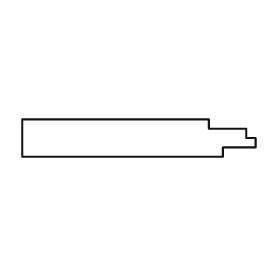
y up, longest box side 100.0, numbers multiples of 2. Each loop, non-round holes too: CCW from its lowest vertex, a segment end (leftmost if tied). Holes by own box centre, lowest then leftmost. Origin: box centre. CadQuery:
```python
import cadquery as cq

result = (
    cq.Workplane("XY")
    .moveTo(-50.0, -8.0)
    .lineTo(36.0, -8.0)
    .lineTo(36.0, -4.0)
    .lineTo(50.0, -4.0)
    .lineTo(50.0, 0.0)
    .lineTo(46.0, 0.0)
    .lineTo(46.0, 4.0)
    .lineTo(30.0, 4.0)
    .lineTo(30.0, 8.0)
    .lineTo(-50.0, 8.0)
    .close()
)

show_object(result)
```